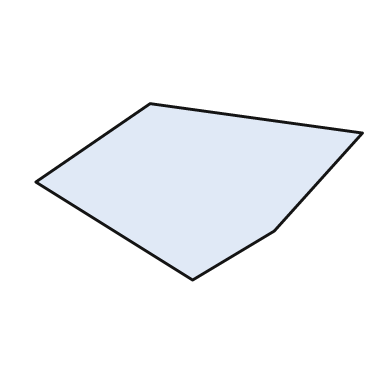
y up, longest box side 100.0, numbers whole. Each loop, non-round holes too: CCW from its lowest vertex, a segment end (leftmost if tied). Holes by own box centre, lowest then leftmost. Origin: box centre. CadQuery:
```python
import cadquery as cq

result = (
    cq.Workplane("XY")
    .moveTo(-2.0, -27.0)
    .lineTo(23.0, -12.0)
    .lineTo(50.0, 18.0)
    .lineTo(-15.0, 27.0)
    .lineTo(-50.0, 3.0)
    .close()
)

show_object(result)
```